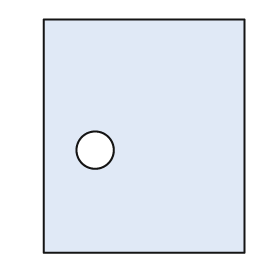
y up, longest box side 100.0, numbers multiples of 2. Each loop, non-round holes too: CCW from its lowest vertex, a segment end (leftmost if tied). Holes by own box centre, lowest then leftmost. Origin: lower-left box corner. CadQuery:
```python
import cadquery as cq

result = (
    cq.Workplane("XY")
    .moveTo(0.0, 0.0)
    .lineTo(86.0, 0.0)
    .lineTo(86.0, 100.0)
    .lineTo(0.0, 100.0)
    .close()
    .moveTo(22.0, 44.0)
    .circle(8.0)
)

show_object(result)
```